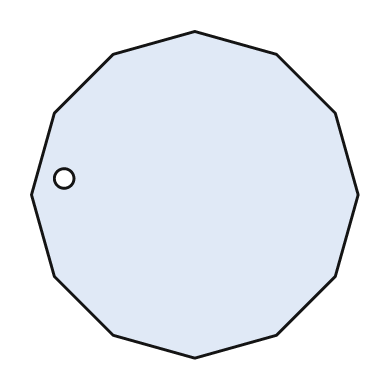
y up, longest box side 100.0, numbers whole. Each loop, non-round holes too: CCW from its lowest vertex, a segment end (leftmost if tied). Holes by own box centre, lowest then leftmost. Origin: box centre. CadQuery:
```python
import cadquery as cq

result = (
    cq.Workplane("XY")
    .moveTo(0.0, -50.0)
    .lineTo(25.0, -43.0)
    .lineTo(43.0, -25.0)
    .lineTo(50.0, 0.0)
    .lineTo(43.0, 25.0)
    .lineTo(25.0, 43.0)
    .lineTo(0.0, 50.0)
    .lineTo(-25.0, 43.0)
    .lineTo(-43.0, 25.0)
    .lineTo(-50.0, 0.0)
    .lineTo(-43.0, -25.0)
    .lineTo(-25.0, -43.0)
    .close()
    .moveTo(-40.0, 5.0)
    .circle(3.0)
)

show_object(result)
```